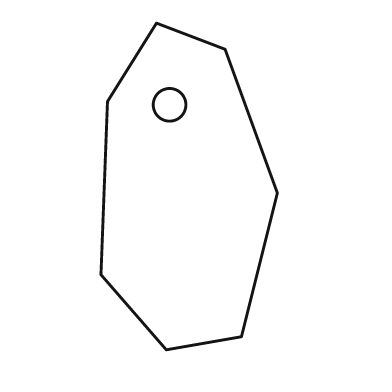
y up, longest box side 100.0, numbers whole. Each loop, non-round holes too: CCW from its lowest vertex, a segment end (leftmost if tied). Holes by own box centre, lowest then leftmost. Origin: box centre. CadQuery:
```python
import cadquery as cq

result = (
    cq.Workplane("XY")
    .moveTo(-7.0, -50.0)
    .lineTo(16.0, -46.0)
    .lineTo(27.0, -2.0)
    .lineTo(11.0, 42.0)
    .lineTo(-10.0, 50.0)
    .lineTo(-25.0, 26.0)
    .lineTo(-27.0, -27.0)
    .close()
    .moveTo(-6.0, 25.0)
    .circle(5.0)
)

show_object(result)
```